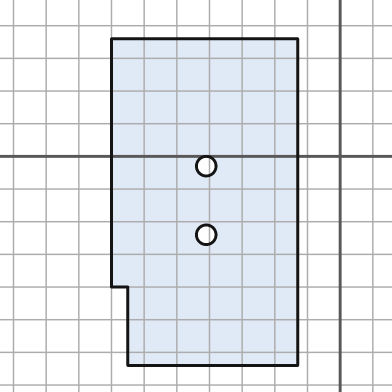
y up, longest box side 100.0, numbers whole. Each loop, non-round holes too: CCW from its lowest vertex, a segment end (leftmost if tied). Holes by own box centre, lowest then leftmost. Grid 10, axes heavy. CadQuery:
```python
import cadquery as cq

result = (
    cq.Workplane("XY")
    .moveTo(-65.0, -64.0)
    .lineTo(-13.0, -64.0)
    .lineTo(-13.0, 36.0)
    .lineTo(-70.0, 36.0)
    .lineTo(-70.0, -40.0)
    .lineTo(-65.0, -40.0)
    .close()
    .moveTo(-41.0, -24.0)
    .circle(3.0)
    .moveTo(-41.0, -3.0)
    .circle(3.0)
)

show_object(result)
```